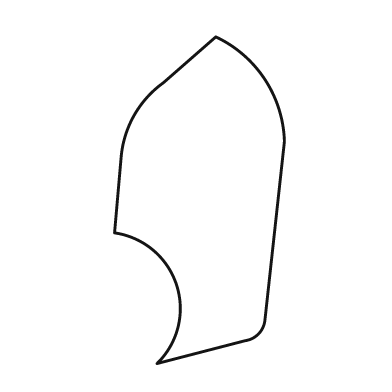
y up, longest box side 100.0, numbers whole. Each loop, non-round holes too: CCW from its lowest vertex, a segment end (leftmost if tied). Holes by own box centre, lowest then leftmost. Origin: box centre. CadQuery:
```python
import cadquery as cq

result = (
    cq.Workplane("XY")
    .moveTo(-13.0, -50.0)
    .lineTo(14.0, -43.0)
    .threePointArc((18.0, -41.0), (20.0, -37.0))
    .lineTo(26.0, 18.0)
    .threePointArc((20.0, 37.0), (5.0, 50.0))
    .lineTo(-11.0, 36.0)
    .threePointArc((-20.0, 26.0), (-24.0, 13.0))
    .lineTo(-26.0, -10.0)
    .threePointArc((-7.0, -26.0), (-13.0, -50.0))
    .close()
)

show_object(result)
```